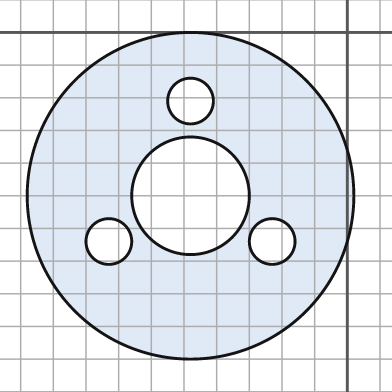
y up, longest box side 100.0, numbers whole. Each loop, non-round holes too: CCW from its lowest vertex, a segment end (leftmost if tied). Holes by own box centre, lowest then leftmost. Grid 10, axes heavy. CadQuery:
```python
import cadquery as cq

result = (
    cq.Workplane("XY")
    .moveTo(-48.0, -50.0)
    .circle(50.0)
    .moveTo(-73.0, -64.0)
    .circle(7.0)
    .moveTo(-23.0, -64.0)
    .circle(7.0)
    .moveTo(-48.0, -50.0)
    .circle(18.0)
    .moveTo(-48.0, -21.0)
    .circle(7.0)
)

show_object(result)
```